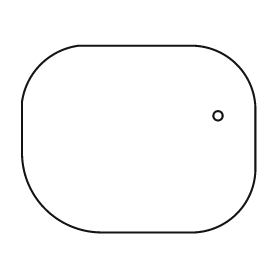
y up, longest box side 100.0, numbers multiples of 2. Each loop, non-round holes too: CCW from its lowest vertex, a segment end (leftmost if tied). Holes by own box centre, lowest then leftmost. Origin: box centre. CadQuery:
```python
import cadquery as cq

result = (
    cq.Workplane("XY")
    .moveTo(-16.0, -40.0)
    .lineTo(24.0, -40.0)
    .threePointArc((42.0, -32.0), (50.0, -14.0))
    .lineTo(50.0, 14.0)
    .threePointArc((42.0, 32.0), (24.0, 40.0))
    .lineTo(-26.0, 40.0)
    .threePointArc((-42.0, 32.0), (-50.0, 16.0))
    .lineTo(-50.0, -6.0)
    .threePointArc((-40.0, -30.0), (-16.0, -40.0))
    .close()
    .moveTo(34.0, 10.0)
    .circle(2.0)
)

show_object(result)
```